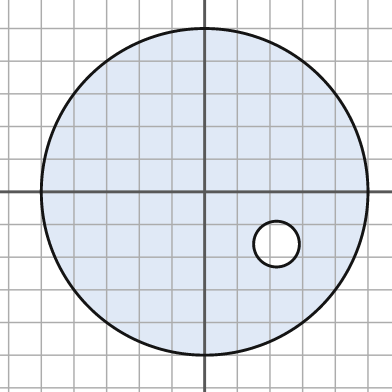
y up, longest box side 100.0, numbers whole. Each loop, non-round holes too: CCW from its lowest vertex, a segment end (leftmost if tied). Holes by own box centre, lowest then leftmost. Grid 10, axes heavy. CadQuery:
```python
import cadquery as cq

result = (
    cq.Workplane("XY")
    .moveTo(0.0, 0.0)
    .circle(50.0)
    .moveTo(22.0, -16.0)
    .circle(7.0)
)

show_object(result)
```